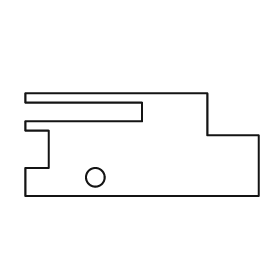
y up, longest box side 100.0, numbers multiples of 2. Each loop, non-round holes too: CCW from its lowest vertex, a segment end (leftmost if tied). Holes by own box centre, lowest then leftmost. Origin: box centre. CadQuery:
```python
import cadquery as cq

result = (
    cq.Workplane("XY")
    .moveTo(-50.0, -22.0)
    .lineTo(50.0, -22.0)
    .lineTo(50.0, 4.0)
    .lineTo(28.0, 4.0)
    .lineTo(28.0, 22.0)
    .lineTo(-50.0, 22.0)
    .lineTo(-50.0, 18.0)
    .lineTo(0.0, 18.0)
    .lineTo(0.0, 10.0)
    .lineTo(-50.0, 10.0)
    .lineTo(-50.0, 6.0)
    .lineTo(-40.0, 6.0)
    .lineTo(-40.0, -10.0)
    .lineTo(-50.0, -10.0)
    .close()
    .moveTo(-20.0, -14.0)
    .circle(4.0)
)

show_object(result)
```